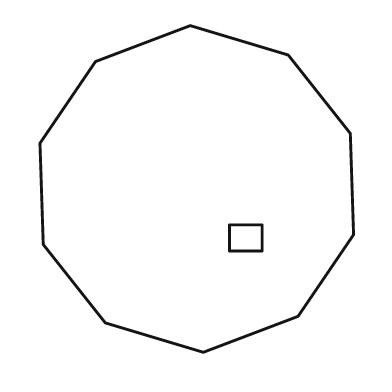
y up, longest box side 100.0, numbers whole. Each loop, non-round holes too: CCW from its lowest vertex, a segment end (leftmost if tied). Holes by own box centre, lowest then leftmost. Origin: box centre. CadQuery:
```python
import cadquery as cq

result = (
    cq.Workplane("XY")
    .moveTo(2.0, -50.0)
    .lineTo(31.0, -39.0)
    .lineTo(48.0, -14.0)
    .lineTo(47.0, 17.0)
    .lineTo(28.0, 41.0)
    .lineTo(-2.0, 50.0)
    .lineTo(-31.0, 39.0)
    .lineTo(-48.0, 14.0)
    .lineTo(-47.0, -17.0)
    .lineTo(-28.0, -41.0)
    .close()
    .moveTo(10.0, -19.0)
    .lineTo(20.0, -19.0)
    .lineTo(20.0, -11.0)
    .lineTo(10.0, -11.0)
    .close()
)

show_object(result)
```